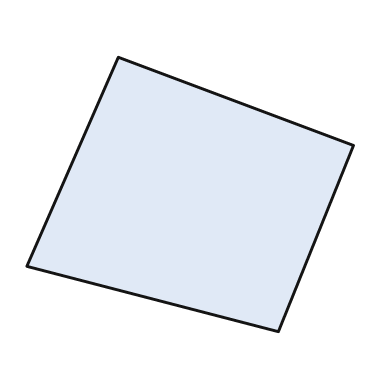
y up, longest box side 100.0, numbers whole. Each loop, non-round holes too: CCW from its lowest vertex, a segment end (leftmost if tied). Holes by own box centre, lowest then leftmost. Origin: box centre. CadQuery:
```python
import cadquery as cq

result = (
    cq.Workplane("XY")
    .moveTo(27.0, -42.0)
    .lineTo(50.0, 15.0)
    .lineTo(-22.0, 42.0)
    .lineTo(-50.0, -22.0)
    .close()
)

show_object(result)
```